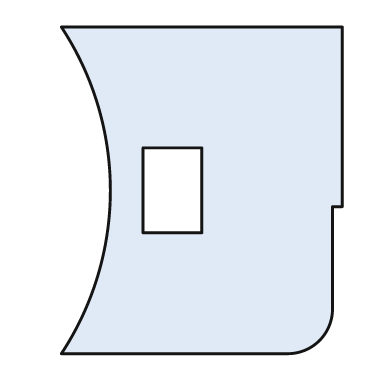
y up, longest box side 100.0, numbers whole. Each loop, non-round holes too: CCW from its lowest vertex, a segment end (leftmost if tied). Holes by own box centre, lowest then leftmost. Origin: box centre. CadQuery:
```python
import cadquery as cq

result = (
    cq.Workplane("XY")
    .moveTo(-43.0, -50.0)
    .lineTo(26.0, -50.0)
    .threePointArc((36.0, -46.0), (40.0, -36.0))
    .lineTo(40.0, -5.0)
    .lineTo(43.0, -5.0)
    .lineTo(43.0, 50.0)
    .lineTo(-43.0, 50.0)
    .threePointArc((-28.0, 0.0), (-43.0, -50.0))
    .close()
    .moveTo(-18.0, -13.0)
    .lineTo(0.0, -13.0)
    .lineTo(0.0, 13.0)
    .lineTo(-18.0, 13.0)
    .close()
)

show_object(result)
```